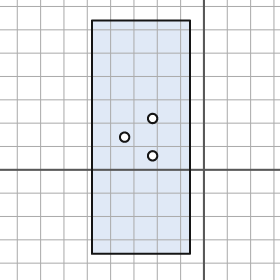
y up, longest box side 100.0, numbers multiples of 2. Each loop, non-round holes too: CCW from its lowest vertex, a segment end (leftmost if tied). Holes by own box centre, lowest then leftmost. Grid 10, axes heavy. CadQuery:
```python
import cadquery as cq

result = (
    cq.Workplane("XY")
    .moveTo(-48.0, -36.0)
    .lineTo(-6.0, -36.0)
    .lineTo(-6.0, 64.0)
    .lineTo(-48.0, 64.0)
    .close()
    .moveTo(-22.0, 6.0)
    .circle(2.0)
    .moveTo(-34.0, 14.0)
    .circle(2.0)
    .moveTo(-22.0, 22.0)
    .circle(2.0)
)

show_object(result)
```